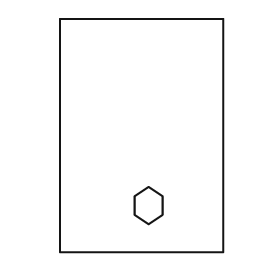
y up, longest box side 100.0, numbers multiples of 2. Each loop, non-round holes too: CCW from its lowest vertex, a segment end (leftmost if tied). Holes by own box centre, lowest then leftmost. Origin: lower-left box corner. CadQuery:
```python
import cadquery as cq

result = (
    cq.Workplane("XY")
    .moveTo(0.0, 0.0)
    .lineTo(70.0, 0.0)
    .lineTo(70.0, 100.0)
    .lineTo(0.0, 100.0)
    .close()
    .moveTo(38.0, 12.0)
    .lineTo(44.0, 16.0)
    .lineTo(44.0, 24.0)
    .lineTo(38.0, 28.0)
    .lineTo(32.0, 24.0)
    .lineTo(32.0, 16.0)
    .close()
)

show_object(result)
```